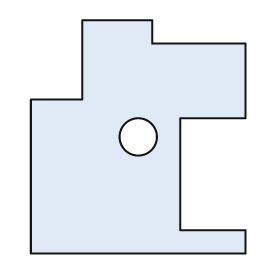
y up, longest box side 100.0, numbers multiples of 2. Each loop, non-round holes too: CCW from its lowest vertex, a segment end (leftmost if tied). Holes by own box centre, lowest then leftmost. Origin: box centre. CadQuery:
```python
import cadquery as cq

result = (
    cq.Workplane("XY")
    .moveTo(-46.0, -50.0)
    .lineTo(46.0, -50.0)
    .lineTo(46.0, -40.0)
    .lineTo(18.0, -40.0)
    .lineTo(18.0, 8.0)
    .lineTo(46.0, 8.0)
    .lineTo(46.0, 40.0)
    .lineTo(6.0, 40.0)
    .lineTo(6.0, 50.0)
    .lineTo(-24.0, 50.0)
    .lineTo(-24.0, 16.0)
    .lineTo(-46.0, 16.0)
    .close()
    .moveTo(0.0, 0.0)
    .circle(8.0)
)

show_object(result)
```